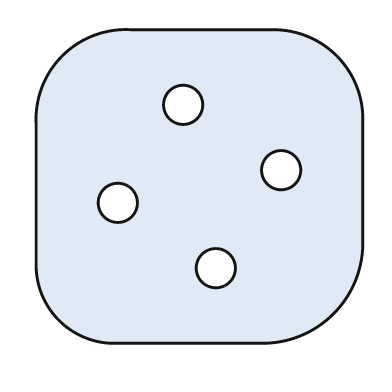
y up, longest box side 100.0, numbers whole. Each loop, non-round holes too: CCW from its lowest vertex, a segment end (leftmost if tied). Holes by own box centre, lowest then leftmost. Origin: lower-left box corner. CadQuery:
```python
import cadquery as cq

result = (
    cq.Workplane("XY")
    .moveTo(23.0, 0.0)
    .lineTo(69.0, 0.0)
    .threePointArc((91.0, 9.0), (100.0, 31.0))
    .lineTo(100.0, 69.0)
    .threePointArc((92.0, 88.0), (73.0, 96.0))
    .lineTo(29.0, 96.0)
    .threePointArc((8.0, 88.0), (0.0, 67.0))
    .lineTo(0.0, 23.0)
    .threePointArc((7.0, 7.0), (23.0, 0.0))
    .close()
    .moveTo(55.0, 23.0)
    .circle(6.0)
    .moveTo(25.0, 43.0)
    .circle(6.0)
    .moveTo(75.0, 53.0)
    .circle(6.0)
    .moveTo(45.0, 73.0)
    .circle(6.0)
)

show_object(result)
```